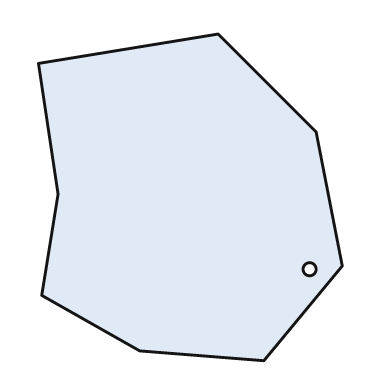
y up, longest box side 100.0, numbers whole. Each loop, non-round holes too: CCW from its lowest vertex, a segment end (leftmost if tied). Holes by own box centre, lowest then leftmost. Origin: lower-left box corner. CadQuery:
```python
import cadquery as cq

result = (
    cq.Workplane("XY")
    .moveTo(69.0, 0.0)
    .lineTo(93.0, 29.0)
    .lineTo(85.0, 70.0)
    .lineTo(55.0, 100.0)
    .lineTo(0.0, 91.0)
    .lineTo(6.0, 51.0)
    .lineTo(1.0, 20.0)
    .lineTo(31.0, 3.0)
    .close()
    .moveTo(83.0, 28.0)
    .circle(2.0)
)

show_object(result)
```